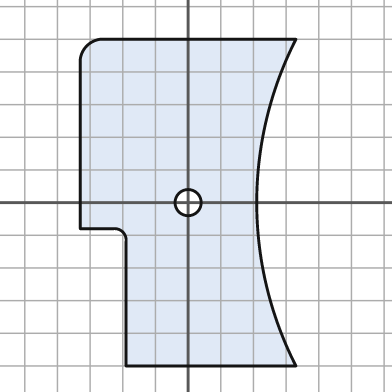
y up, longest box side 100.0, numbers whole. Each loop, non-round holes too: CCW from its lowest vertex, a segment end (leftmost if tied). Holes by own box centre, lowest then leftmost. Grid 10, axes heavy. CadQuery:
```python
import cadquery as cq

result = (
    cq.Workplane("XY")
    .moveTo(-19.0, -50.0)
    .lineTo(33.0, -50.0)
    .threePointArc((21.0, 0.0), (33.0, 50.0))
    .lineTo(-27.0, 50.0)
    .threePointArc((-31.0, 48.0), (-33.0, 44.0))
    .lineTo(-33.0, -8.0)
    .lineTo(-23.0, -8.0)
    .threePointArc((-20.0, -9.0), (-19.0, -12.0))
    .close()
    .moveTo(0.0, 0.0)
    .circle(4.0)
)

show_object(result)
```